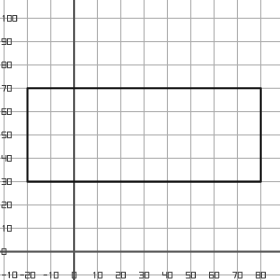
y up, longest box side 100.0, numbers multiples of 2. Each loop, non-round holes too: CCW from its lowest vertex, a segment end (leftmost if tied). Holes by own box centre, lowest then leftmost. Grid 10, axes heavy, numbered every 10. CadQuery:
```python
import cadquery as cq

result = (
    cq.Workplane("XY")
    .moveTo(-20.0, 30.0)
    .lineTo(80.0, 30.0)
    .lineTo(80.0, 70.0)
    .lineTo(-20.0, 70.0)
    .close()
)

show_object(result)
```